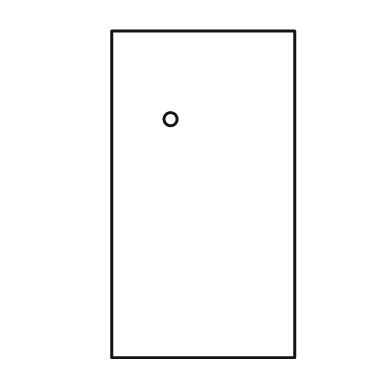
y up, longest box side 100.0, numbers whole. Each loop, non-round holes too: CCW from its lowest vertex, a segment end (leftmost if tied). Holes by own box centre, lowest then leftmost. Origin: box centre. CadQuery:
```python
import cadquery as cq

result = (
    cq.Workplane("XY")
    .moveTo(-28.0, -50.0)
    .lineTo(28.0, -50.0)
    .lineTo(28.0, 50.0)
    .lineTo(-28.0, 50.0)
    .close()
    .moveTo(-10.0, 23.0)
    .circle(2.0)
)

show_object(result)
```